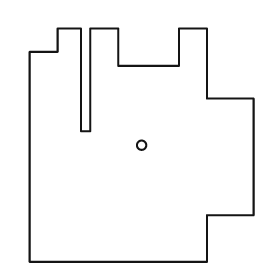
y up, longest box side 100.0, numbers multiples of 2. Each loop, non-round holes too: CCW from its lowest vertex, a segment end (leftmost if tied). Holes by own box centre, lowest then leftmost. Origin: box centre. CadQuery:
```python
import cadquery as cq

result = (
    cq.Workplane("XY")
    .moveTo(-48.0, -50.0)
    .lineTo(28.0, -50.0)
    .lineTo(28.0, -30.0)
    .lineTo(48.0, -30.0)
    .lineTo(48.0, 20.0)
    .lineTo(28.0, 20.0)
    .lineTo(28.0, 50.0)
    .lineTo(16.0, 50.0)
    .lineTo(16.0, 34.0)
    .lineTo(-10.0, 34.0)
    .lineTo(-10.0, 50.0)
    .lineTo(-22.0, 50.0)
    .lineTo(-22.0, 6.0)
    .lineTo(-26.0, 6.0)
    .lineTo(-26.0, 50.0)
    .lineTo(-36.0, 50.0)
    .lineTo(-36.0, 40.0)
    .lineTo(-48.0, 40.0)
    .close()
    .moveTo(0.0, 0.0)
    .circle(2.0)
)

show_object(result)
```